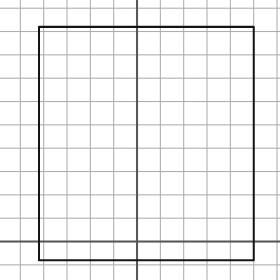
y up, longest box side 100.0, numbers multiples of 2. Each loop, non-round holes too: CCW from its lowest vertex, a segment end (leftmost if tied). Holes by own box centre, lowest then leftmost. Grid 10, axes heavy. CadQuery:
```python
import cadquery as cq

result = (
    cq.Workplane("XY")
    .moveTo(-42.0, -8.0)
    .lineTo(50.0, -8.0)
    .lineTo(50.0, 92.0)
    .lineTo(-42.0, 92.0)
    .close()
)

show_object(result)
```